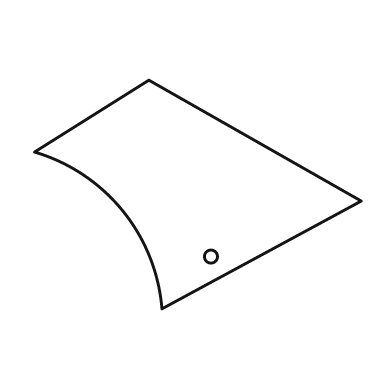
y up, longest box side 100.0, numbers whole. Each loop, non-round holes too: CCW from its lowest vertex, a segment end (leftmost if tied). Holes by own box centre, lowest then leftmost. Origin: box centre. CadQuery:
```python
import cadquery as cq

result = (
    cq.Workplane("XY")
    .moveTo(-11.0, -35.0)
    .lineTo(50.0, -2.0)
    .lineTo(-15.0, 35.0)
    .lineTo(-50.0, 13.0)
    .threePointArc((-23.0, -5.0), (-11.0, -35.0))
    .close()
    .moveTo(4.0, -19.0)
    .circle(2.0)
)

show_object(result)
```